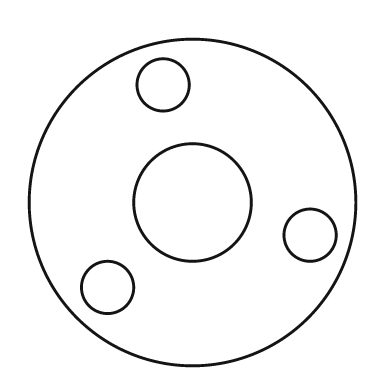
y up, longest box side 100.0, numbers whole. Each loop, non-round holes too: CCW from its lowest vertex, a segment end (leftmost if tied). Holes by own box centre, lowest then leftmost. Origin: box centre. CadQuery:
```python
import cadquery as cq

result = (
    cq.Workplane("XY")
    .moveTo(0.0, 0.0)
    .circle(50.0)
    .moveTo(-26.0, -26.0)
    .circle(8.0)
    .moveTo(36.0, -10.0)
    .circle(8.0)
    .moveTo(0.0, 0.0)
    .circle(18.0)
    .moveTo(-9.0, 36.0)
    .circle(8.0)
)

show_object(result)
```